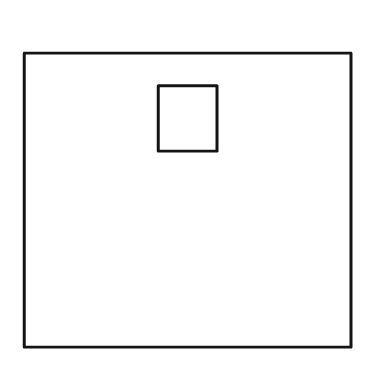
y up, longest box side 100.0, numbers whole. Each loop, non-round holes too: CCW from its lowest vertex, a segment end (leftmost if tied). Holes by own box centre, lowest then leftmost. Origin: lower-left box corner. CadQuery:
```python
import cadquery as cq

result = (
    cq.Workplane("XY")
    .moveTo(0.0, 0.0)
    .lineTo(100.0, 0.0)
    .lineTo(100.0, 90.0)
    .lineTo(0.0, 90.0)
    .close()
    .moveTo(41.0, 60.0)
    .lineTo(59.0, 60.0)
    .lineTo(59.0, 80.0)
    .lineTo(41.0, 80.0)
    .close()
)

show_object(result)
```